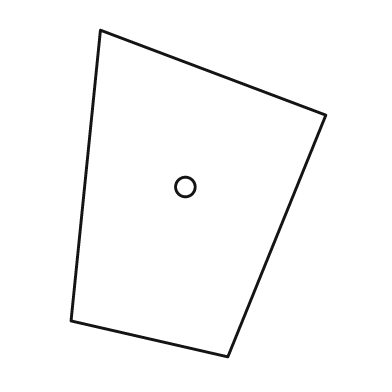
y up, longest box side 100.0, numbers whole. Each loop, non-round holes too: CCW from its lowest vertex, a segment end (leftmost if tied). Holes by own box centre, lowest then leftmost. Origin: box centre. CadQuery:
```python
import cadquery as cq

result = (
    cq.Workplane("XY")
    .moveTo(9.0, -50.0)
    .lineTo(39.0, 24.0)
    .lineTo(-30.0, 50.0)
    .lineTo(-39.0, -39.0)
    .close()
    .moveTo(-4.0, 2.0)
    .circle(3.0)
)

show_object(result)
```